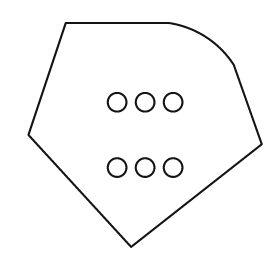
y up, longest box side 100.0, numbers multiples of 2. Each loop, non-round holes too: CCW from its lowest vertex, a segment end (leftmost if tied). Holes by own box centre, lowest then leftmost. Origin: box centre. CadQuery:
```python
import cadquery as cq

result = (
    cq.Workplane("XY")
    .moveTo(-6.0, -48.0)
    .lineTo(50.0, -4.0)
    .lineTo(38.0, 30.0)
    .threePointArc((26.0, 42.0), (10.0, 48.0))
    .lineTo(-34.0, 48.0)
    .lineTo(-50.0, 0.0)
    .close()
    .moveTo(-12.0, -14.0)
    .circle(4.0)
    .moveTo(0.0, -14.0)
    .circle(4.0)
    .moveTo(12.0, -14.0)
    .circle(4.0)
    .moveTo(-12.0, 14.0)
    .circle(4.0)
    .moveTo(0.0, 14.0)
    .circle(4.0)
    .moveTo(12.0, 14.0)
    .circle(4.0)
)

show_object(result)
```